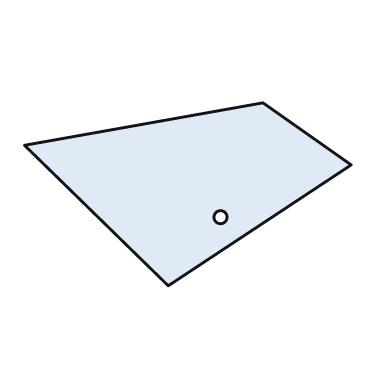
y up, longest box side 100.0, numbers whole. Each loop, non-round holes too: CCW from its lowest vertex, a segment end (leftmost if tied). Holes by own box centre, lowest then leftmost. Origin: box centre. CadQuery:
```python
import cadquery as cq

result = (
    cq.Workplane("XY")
    .moveTo(-6.0, -28.0)
    .lineTo(50.0, 9.0)
    .lineTo(23.0, 28.0)
    .lineTo(-50.0, 15.0)
    .close()
    .moveTo(10.0, -7.0)
    .circle(2.0)
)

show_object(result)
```